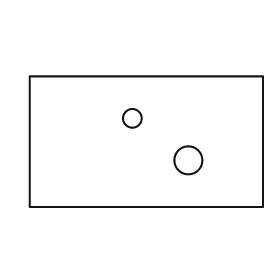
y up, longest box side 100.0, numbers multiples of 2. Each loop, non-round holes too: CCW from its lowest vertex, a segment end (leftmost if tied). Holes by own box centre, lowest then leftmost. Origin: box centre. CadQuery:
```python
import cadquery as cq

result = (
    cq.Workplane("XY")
    .moveTo(-50.0, -28.0)
    .lineTo(50.0, -28.0)
    .lineTo(50.0, 28.0)
    .lineTo(-50.0, 28.0)
    .close()
    .moveTo(18.0, -8.0)
    .circle(6.0)
    .moveTo(-6.0, 10.0)
    .circle(4.0)
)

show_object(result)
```